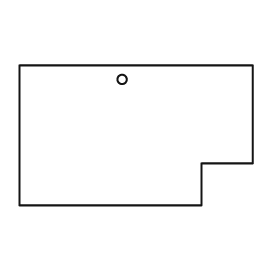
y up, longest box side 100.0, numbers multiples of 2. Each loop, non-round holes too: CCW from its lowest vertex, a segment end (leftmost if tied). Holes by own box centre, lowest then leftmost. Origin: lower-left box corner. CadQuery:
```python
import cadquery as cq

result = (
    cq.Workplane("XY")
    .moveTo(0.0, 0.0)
    .lineTo(78.0, 0.0)
    .lineTo(78.0, 18.0)
    .lineTo(100.0, 18.0)
    .lineTo(100.0, 60.0)
    .lineTo(0.0, 60.0)
    .close()
    .moveTo(44.0, 54.0)
    .circle(2.0)
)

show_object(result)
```